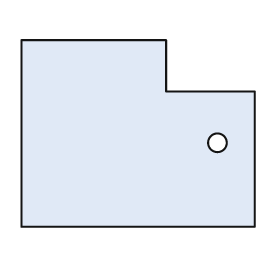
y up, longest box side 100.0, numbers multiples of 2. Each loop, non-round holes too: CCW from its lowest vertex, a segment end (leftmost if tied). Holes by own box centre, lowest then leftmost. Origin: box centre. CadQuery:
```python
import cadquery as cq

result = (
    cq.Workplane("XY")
    .moveTo(-50.0, -40.0)
    .lineTo(50.0, -40.0)
    .lineTo(50.0, 18.0)
    .lineTo(12.0, 18.0)
    .lineTo(12.0, 40.0)
    .lineTo(-50.0, 40.0)
    .close()
    .moveTo(34.0, -4.0)
    .circle(4.0)
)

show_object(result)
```